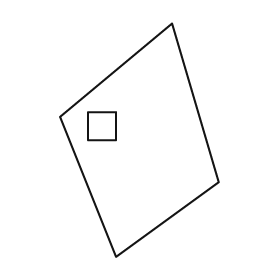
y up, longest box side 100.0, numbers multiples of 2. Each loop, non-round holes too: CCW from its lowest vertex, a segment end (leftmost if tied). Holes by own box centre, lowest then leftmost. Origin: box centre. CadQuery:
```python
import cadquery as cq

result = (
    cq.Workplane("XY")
    .moveTo(-10.0, -50.0)
    .lineTo(34.0, -18.0)
    .lineTo(14.0, 50.0)
    .lineTo(-34.0, 10.0)
    .close()
    .moveTo(-22.0, 0.0)
    .lineTo(-10.0, 0.0)
    .lineTo(-10.0, 12.0)
    .lineTo(-22.0, 12.0)
    .close()
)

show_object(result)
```